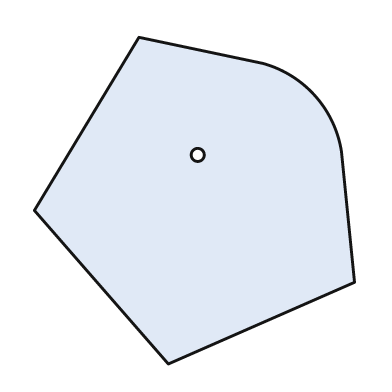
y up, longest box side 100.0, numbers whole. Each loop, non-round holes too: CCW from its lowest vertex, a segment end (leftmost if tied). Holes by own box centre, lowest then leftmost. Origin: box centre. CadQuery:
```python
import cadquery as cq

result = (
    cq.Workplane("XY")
    .moveTo(-8.0, -50.0)
    .lineTo(49.0, -25.0)
    .lineTo(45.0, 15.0)
    .threePointArc((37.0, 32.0), (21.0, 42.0))
    .lineTo(-17.0, 50.0)
    .lineTo(-49.0, -3.0)
    .close()
    .moveTo(1.0, 14.0)
    .circle(2.0)
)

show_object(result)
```